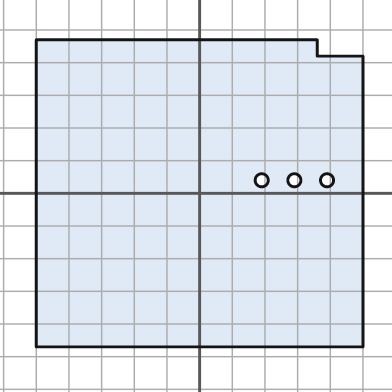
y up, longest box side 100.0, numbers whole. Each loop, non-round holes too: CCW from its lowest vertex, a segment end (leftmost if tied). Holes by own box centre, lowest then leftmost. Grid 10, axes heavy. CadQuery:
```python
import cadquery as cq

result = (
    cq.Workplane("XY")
    .moveTo(-50.0, -47.0)
    .lineTo(50.0, -47.0)
    .lineTo(50.0, 42.0)
    .lineTo(36.0, 42.0)
    .lineTo(36.0, 47.0)
    .lineTo(-50.0, 47.0)
    .close()
    .moveTo(19.0, 4.0)
    .circle(2.0)
    .moveTo(29.0, 4.0)
    .circle(2.0)
    .moveTo(39.0, 4.0)
    .circle(2.0)
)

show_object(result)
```